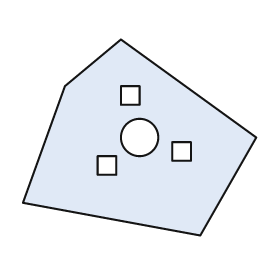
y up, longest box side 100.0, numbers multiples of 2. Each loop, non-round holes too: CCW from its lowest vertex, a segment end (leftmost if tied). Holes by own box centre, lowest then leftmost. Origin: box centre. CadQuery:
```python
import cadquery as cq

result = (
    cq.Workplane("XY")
    .moveTo(26.0, -42.0)
    .lineTo(50.0, 0.0)
    .lineTo(-8.0, 42.0)
    .lineTo(-32.0, 22.0)
    .lineTo(-50.0, -28.0)
    .close()
    .moveTo(-18.0, -16.0)
    .lineTo(-10.0, -16.0)
    .lineTo(-10.0, -8.0)
    .lineTo(-18.0, -8.0)
    .close()
    .moveTo(14.0, -10.0)
    .lineTo(22.0, -10.0)
    .lineTo(22.0, -2.0)
    .lineTo(14.0, -2.0)
    .close()
    .moveTo(0.0, 0.0)
    .circle(8.0)
    .moveTo(-8.0, 14.0)
    .lineTo(0.0, 14.0)
    .lineTo(0.0, 22.0)
    .lineTo(-8.0, 22.0)
    .close()
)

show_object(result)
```